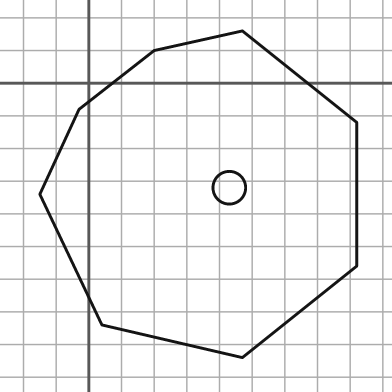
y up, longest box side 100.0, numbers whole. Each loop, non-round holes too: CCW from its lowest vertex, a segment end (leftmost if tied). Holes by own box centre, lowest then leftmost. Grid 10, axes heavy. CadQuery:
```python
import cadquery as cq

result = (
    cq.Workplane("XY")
    .moveTo(47.0, -84.0)
    .lineTo(82.0, -56.0)
    .lineTo(82.0, -12.0)
    .lineTo(47.0, 16.0)
    .lineTo(20.0, 10.0)
    .lineTo(-3.0, -8.0)
    .lineTo(-15.0, -34.0)
    .lineTo(4.0, -74.0)
    .close()
    .moveTo(43.0, -32.0)
    .circle(5.0)
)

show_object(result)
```